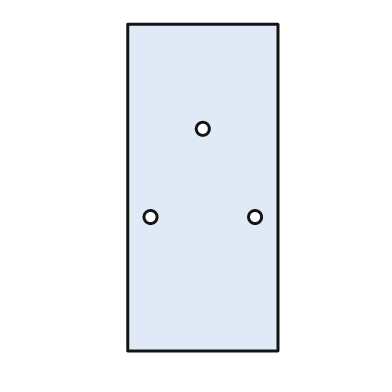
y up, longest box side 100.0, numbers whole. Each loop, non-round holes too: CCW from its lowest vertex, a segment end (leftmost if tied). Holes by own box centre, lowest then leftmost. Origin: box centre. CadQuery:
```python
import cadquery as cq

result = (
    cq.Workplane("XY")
    .moveTo(-23.0, -50.0)
    .lineTo(23.0, -50.0)
    .lineTo(23.0, 50.0)
    .lineTo(-23.0, 50.0)
    .close()
    .moveTo(-16.0, -9.0)
    .circle(2.0)
    .moveTo(16.0, -9.0)
    .circle(2.0)
    .moveTo(0.0, 18.0)
    .circle(2.0)
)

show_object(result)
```